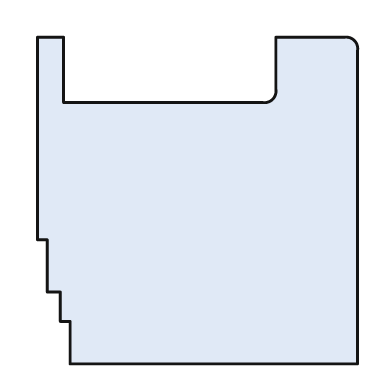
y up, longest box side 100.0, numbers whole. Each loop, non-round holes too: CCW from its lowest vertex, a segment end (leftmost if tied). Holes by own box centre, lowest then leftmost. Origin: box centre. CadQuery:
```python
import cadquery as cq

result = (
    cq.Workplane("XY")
    .moveTo(-39.0, -50.0)
    .lineTo(49.0, -50.0)
    .lineTo(49.0, 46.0)
    .threePointArc((48.0, 49.0), (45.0, 50.0))
    .lineTo(24.0, 50.0)
    .lineTo(24.0, 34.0)
    .threePointArc((23.0, 31.0), (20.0, 30.0))
    .lineTo(-41.0, 30.0)
    .lineTo(-41.0, 50.0)
    .lineTo(-49.0, 50.0)
    .lineTo(-49.0, -12.0)
    .lineTo(-46.0, -12.0)
    .lineTo(-46.0, -28.0)
    .lineTo(-42.0, -28.0)
    .lineTo(-42.0, -37.0)
    .lineTo(-39.0, -37.0)
    .close()
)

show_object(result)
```